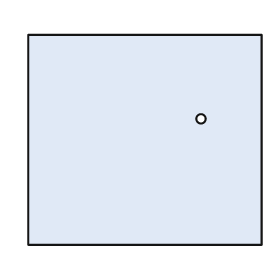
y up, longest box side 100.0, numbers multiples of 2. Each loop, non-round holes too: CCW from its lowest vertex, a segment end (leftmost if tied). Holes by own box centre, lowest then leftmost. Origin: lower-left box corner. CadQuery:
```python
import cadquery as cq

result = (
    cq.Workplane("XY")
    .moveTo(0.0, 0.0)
    .lineTo(100.0, 0.0)
    .lineTo(100.0, 90.0)
    .lineTo(0.0, 90.0)
    .close()
    .moveTo(74.0, 54.0)
    .circle(2.0)
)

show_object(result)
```